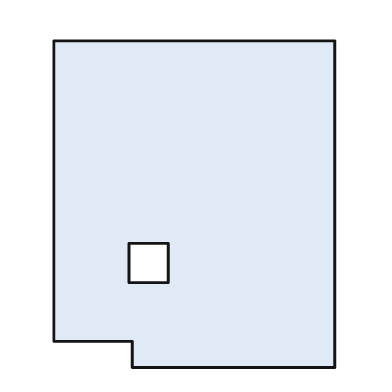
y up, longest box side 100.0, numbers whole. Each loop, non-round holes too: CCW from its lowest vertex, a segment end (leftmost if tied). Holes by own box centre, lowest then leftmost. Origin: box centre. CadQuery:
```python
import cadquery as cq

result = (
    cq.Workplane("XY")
    .moveTo(-19.0, -50.0)
    .lineTo(43.0, -50.0)
    .lineTo(43.0, 50.0)
    .lineTo(-43.0, 50.0)
    .lineTo(-43.0, -42.0)
    .lineTo(-19.0, -42.0)
    .close()
    .moveTo(-20.0, -24.0)
    .lineTo(-8.0, -24.0)
    .lineTo(-8.0, -12.0)
    .lineTo(-20.0, -12.0)
    .close()
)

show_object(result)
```